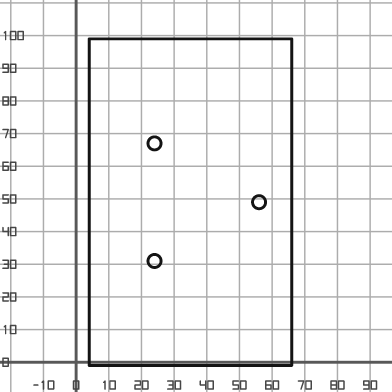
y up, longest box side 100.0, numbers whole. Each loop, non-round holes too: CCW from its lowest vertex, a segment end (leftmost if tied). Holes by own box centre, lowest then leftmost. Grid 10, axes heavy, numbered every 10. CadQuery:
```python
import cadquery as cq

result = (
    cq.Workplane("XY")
    .moveTo(4.0, -1.0)
    .lineTo(66.0, -1.0)
    .lineTo(66.0, 99.0)
    .lineTo(4.0, 99.0)
    .close()
    .moveTo(24.0, 31.0)
    .circle(2.0)
    .moveTo(56.0, 49.0)
    .circle(2.0)
    .moveTo(24.0, 67.0)
    .circle(2.0)
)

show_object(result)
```